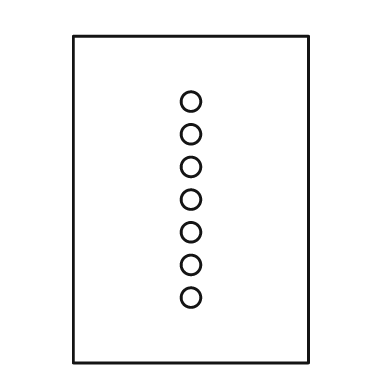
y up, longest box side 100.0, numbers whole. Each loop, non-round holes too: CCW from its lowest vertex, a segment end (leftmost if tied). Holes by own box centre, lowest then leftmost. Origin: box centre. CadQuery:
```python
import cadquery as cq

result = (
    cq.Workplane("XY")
    .moveTo(-36.0, -50.0)
    .lineTo(36.0, -50.0)
    .lineTo(36.0, 50.0)
    .lineTo(-36.0, 50.0)
    .close()
    .moveTo(0.0, -30.0)
    .circle(3.0)
    .moveTo(0.0, -20.0)
    .circle(3.0)
    .moveTo(0.0, -10.0)
    .circle(3.0)
    .moveTo(0.0, 0.0)
    .circle(3.0)
    .moveTo(0.0, 10.0)
    .circle(3.0)
    .moveTo(0.0, 20.0)
    .circle(3.0)
    .moveTo(0.0, 30.0)
    .circle(3.0)
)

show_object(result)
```